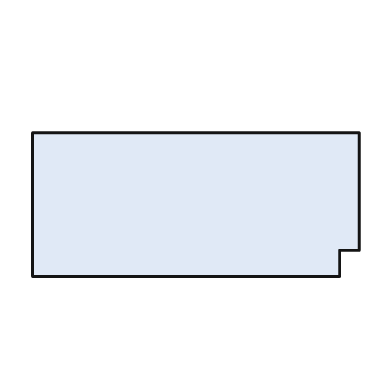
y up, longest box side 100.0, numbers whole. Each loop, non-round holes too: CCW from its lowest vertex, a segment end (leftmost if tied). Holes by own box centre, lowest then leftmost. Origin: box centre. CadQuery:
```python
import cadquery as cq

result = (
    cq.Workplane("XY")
    .moveTo(-50.0, -22.0)
    .lineTo(44.0, -22.0)
    .lineTo(44.0, -14.0)
    .lineTo(50.0, -14.0)
    .lineTo(50.0, 22.0)
    .lineTo(-50.0, 22.0)
    .close()
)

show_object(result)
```